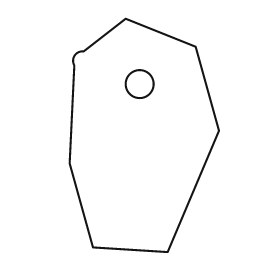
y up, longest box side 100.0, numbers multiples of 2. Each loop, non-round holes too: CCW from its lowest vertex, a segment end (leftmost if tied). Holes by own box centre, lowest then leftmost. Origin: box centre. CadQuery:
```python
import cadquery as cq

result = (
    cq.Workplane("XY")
    .moveTo(10.0, -50.0)
    .lineTo(32.0, 2.0)
    .lineTo(22.0, 38.0)
    .lineTo(-8.0, 50.0)
    .lineTo(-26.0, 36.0)
    .threePointArc((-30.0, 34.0), (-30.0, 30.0))
    .lineTo(-32.0, -12.0)
    .lineTo(-22.0, -48.0)
    .close()
    .moveTo(-2.0, 22.0)
    .circle(6.0)
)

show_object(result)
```